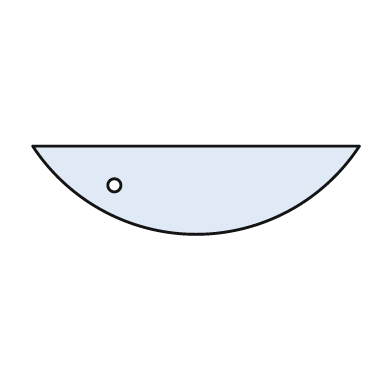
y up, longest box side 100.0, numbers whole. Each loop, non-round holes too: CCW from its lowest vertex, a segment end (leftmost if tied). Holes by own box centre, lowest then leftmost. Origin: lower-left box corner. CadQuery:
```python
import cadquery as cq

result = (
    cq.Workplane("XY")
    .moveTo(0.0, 27.0)
    .threePointArc((50.0, 0.0), (100.0, 27.0))
    .close()
    .moveTo(25.0, 15.0)
    .circle(2.0)
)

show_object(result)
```